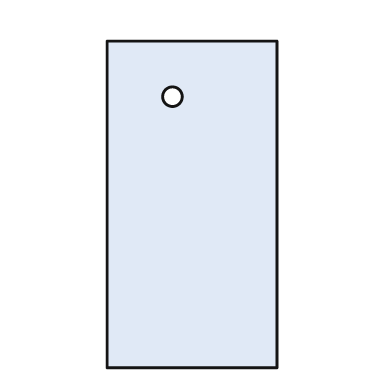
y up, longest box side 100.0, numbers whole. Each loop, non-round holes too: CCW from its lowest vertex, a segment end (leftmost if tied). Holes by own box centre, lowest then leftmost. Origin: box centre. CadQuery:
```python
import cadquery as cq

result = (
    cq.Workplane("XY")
    .moveTo(-26.0, -50.0)
    .lineTo(26.0, -50.0)
    .lineTo(26.0, 50.0)
    .lineTo(-26.0, 50.0)
    .close()
    .moveTo(-6.0, 33.0)
    .circle(3.0)
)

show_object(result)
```